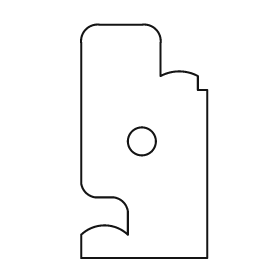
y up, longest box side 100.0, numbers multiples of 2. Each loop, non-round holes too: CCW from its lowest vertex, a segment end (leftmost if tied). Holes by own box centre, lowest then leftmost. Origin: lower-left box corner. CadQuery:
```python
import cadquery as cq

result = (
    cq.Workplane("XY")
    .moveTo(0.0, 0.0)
    .lineTo(54.0, 0.0)
    .lineTo(54.0, 72.0)
    .lineTo(50.0, 72.0)
    .lineTo(50.0, 78.0)
    .threePointArc((42.0, 80.0), (34.0, 78.0))
    .lineTo(34.0, 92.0)
    .threePointArc((32.0, 98.0), (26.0, 100.0))
    .lineTo(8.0, 100.0)
    .threePointArc((2.0, 98.0), (0.0, 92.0))
    .lineTo(0.0, 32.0)
    .threePointArc((2.0, 28.0), (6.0, 26.0))
    .lineTo(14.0, 26.0)
    .threePointArc((18.0, 24.0), (20.0, 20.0))
    .lineTo(20.0, 10.0)
    .threePointArc((10.0, 14.0), (0.0, 10.0))
    .close()
    .moveTo(26.0, 50.0)
    .circle(6.0)
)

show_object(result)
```